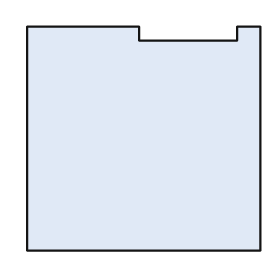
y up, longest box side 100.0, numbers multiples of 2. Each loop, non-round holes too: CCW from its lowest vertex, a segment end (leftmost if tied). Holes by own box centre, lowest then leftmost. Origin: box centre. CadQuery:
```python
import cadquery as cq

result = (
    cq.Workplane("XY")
    .moveTo(-50.0, -48.0)
    .lineTo(50.0, -48.0)
    .lineTo(50.0, 48.0)
    .lineTo(40.0, 48.0)
    .lineTo(40.0, 42.0)
    .lineTo(-2.0, 42.0)
    .lineTo(-2.0, 48.0)
    .lineTo(-50.0, 48.0)
    .close()
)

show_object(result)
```